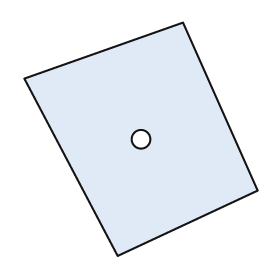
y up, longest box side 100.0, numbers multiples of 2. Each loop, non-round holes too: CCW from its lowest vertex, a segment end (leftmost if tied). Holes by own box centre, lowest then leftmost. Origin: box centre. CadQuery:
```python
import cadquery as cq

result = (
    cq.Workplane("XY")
    .moveTo(-10.0, -50.0)
    .lineTo(50.0, -22.0)
    .lineTo(18.0, 50.0)
    .lineTo(-50.0, 26.0)
    .close()
    .moveTo(0.0, 0.0)
    .circle(4.0)
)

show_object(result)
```